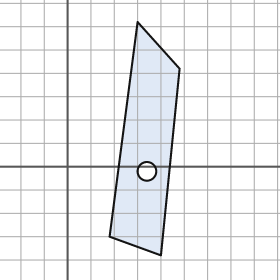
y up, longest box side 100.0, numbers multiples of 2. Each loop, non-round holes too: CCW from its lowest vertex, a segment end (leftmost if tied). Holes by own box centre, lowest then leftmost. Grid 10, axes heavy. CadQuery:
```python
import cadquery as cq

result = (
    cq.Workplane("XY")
    .moveTo(40.0, -38.0)
    .lineTo(48.0, 42.0)
    .lineTo(30.0, 62.0)
    .lineTo(18.0, -30.0)
    .close()
    .moveTo(34.0, -2.0)
    .circle(4.0)
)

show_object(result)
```